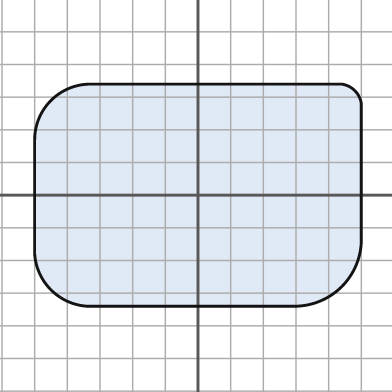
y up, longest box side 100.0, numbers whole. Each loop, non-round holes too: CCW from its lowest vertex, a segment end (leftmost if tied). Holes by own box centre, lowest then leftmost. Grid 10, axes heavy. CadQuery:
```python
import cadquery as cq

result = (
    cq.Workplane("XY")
    .moveTo(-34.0, -34.0)
    .lineTo(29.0, -34.0)
    .threePointArc((44.0, -28.0), (50.0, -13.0))
    .lineTo(50.0, 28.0)
    .threePointArc((48.0, 32.0), (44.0, 34.0))
    .lineTo(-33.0, 34.0)
    .threePointArc((-45.0, 29.0), (-50.0, 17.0))
    .lineTo(-50.0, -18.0)
    .threePointArc((-45.0, -29.0), (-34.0, -34.0))
    .close()
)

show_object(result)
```